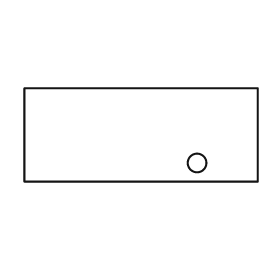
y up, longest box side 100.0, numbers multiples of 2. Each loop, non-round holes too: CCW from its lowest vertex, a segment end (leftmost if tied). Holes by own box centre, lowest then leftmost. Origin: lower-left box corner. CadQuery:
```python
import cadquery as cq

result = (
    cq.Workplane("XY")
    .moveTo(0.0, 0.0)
    .lineTo(100.0, 0.0)
    .lineTo(100.0, 40.0)
    .lineTo(0.0, 40.0)
    .close()
    .moveTo(74.0, 8.0)
    .circle(4.0)
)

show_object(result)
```